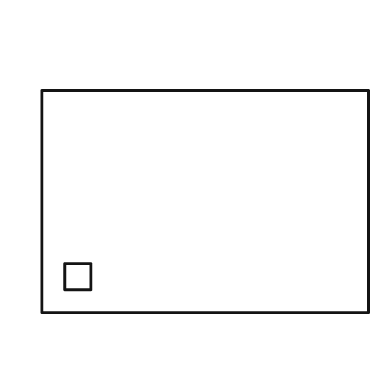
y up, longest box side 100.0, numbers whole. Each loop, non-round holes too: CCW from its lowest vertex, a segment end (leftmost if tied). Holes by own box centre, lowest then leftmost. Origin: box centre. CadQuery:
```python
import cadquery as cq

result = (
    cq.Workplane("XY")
    .moveTo(-50.0, -34.0)
    .lineTo(50.0, -34.0)
    .lineTo(50.0, 34.0)
    .lineTo(-50.0, 34.0)
    .close()
    .moveTo(-43.0, -27.0)
    .lineTo(-35.0, -27.0)
    .lineTo(-35.0, -19.0)
    .lineTo(-43.0, -19.0)
    .close()
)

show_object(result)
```